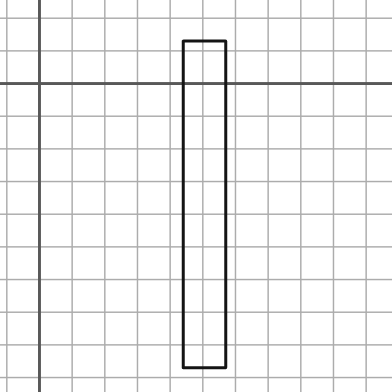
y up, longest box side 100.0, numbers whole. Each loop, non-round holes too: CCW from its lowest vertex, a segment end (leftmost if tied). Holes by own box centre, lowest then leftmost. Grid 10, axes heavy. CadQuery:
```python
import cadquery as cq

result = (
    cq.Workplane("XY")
    .moveTo(44.0, -87.0)
    .lineTo(57.0, -87.0)
    .lineTo(57.0, 13.0)
    .lineTo(44.0, 13.0)
    .close()
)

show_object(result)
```